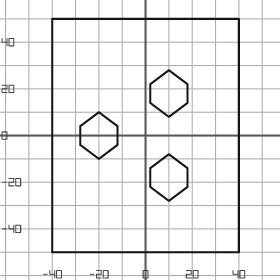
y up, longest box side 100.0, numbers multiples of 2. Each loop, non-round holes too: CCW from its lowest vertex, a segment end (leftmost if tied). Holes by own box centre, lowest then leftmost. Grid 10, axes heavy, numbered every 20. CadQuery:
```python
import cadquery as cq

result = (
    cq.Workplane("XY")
    .moveTo(-40.0, -50.0)
    .lineTo(40.0, -50.0)
    .lineTo(40.0, 50.0)
    .lineTo(-40.0, 50.0)
    .close()
    .moveTo(10.0, -28.0)
    .lineTo(18.0, -22.0)
    .lineTo(18.0, -14.0)
    .lineTo(10.0, -8.0)
    .lineTo(2.0, -14.0)
    .lineTo(2.0, -22.0)
    .close()
    .moveTo(-20.0, -10.0)
    .lineTo(-12.0, -4.0)
    .lineTo(-12.0, 4.0)
    .lineTo(-20.0, 10.0)
    .lineTo(-28.0, 4.0)
    .lineTo(-28.0, -4.0)
    .close()
    .moveTo(10.0, 8.0)
    .lineTo(18.0, 14.0)
    .lineTo(18.0, 22.0)
    .lineTo(10.0, 28.0)
    .lineTo(2.0, 22.0)
    .lineTo(2.0, 14.0)
    .close()
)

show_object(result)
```